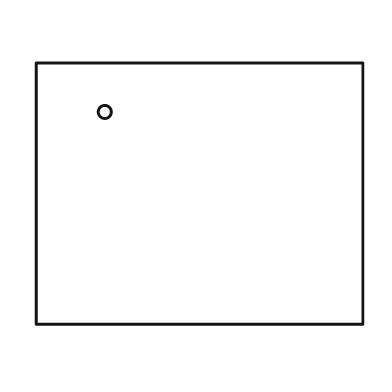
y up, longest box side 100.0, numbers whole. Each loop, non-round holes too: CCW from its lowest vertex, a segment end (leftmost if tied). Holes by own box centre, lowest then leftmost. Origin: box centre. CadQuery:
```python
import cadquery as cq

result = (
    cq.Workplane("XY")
    .moveTo(-50.0, -40.0)
    .lineTo(50.0, -40.0)
    .lineTo(50.0, 40.0)
    .lineTo(-50.0, 40.0)
    .close()
    .moveTo(-29.0, 25.0)
    .circle(2.0)
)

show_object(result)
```